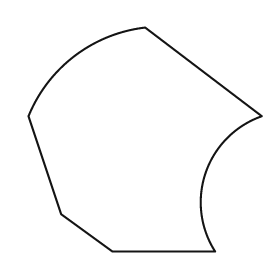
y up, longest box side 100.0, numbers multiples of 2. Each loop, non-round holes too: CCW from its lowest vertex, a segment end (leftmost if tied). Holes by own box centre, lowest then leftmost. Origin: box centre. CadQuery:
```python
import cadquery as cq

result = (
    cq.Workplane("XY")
    .moveTo(-14.0, -48.0)
    .lineTo(30.0, -48.0)
    .threePointArc((26.0, -14.0), (50.0, 10.0))
    .lineTo(0.0, 48.0)
    .threePointArc((-30.0, 36.0), (-50.0, 10.0))
    .lineTo(-36.0, -32.0)
    .close()
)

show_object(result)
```